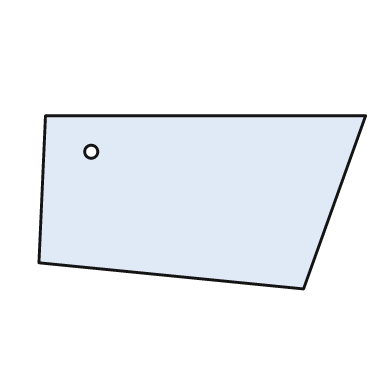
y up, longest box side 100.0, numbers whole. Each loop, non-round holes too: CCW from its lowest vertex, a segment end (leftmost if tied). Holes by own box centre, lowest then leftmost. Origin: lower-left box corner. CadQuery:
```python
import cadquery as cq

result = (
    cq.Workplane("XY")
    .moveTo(81.0, 0.0)
    .lineTo(100.0, 53.0)
    .lineTo(2.0, 53.0)
    .lineTo(0.0, 8.0)
    .close()
    .moveTo(16.0, 42.0)
    .circle(2.0)
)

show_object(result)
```